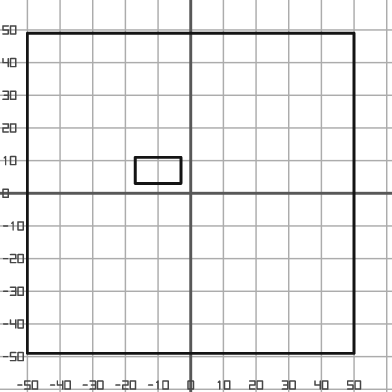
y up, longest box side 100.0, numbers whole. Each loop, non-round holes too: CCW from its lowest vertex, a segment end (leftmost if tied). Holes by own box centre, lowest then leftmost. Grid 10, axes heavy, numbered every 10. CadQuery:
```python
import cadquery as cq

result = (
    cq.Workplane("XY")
    .moveTo(-50.0, -49.0)
    .lineTo(50.0, -49.0)
    .lineTo(50.0, 49.0)
    .lineTo(-50.0, 49.0)
    .close()
    .moveTo(-17.0, 3.0)
    .lineTo(-3.0, 3.0)
    .lineTo(-3.0, 11.0)
    .lineTo(-17.0, 11.0)
    .close()
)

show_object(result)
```